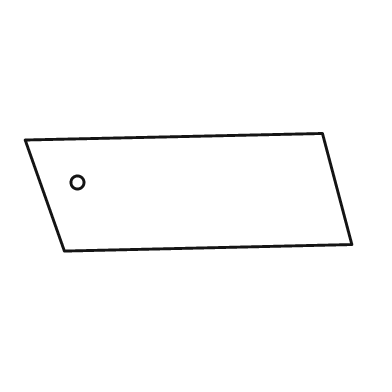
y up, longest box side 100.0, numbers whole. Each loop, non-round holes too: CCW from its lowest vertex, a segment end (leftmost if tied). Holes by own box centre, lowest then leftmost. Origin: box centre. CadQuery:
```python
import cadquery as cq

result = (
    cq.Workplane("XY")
    .moveTo(-38.0, -18.0)
    .lineTo(50.0, -16.0)
    .lineTo(41.0, 18.0)
    .lineTo(-50.0, 16.0)
    .close()
    .moveTo(-34.0, 3.0)
    .circle(2.0)
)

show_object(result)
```